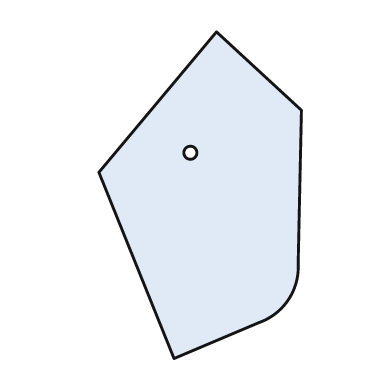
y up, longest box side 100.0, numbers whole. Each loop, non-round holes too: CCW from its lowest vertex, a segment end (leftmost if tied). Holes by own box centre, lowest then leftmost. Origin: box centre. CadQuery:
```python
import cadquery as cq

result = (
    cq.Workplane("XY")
    .moveTo(-8.0, -50.0)
    .lineTo(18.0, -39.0)
    .threePointArc((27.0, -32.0), (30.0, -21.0))
    .lineTo(31.0, 26.0)
    .lineTo(5.0, 50.0)
    .lineTo(-31.0, 7.0)
    .close()
    .moveTo(-3.0, 13.0)
    .circle(2.0)
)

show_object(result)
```